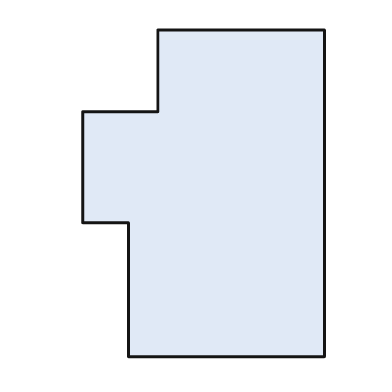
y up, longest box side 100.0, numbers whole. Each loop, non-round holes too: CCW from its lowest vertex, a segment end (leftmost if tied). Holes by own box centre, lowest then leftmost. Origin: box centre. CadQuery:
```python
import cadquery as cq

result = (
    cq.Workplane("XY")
    .moveTo(-23.0, -50.0)
    .lineTo(37.0, -50.0)
    .lineTo(37.0, 50.0)
    .lineTo(-14.0, 50.0)
    .lineTo(-14.0, 25.0)
    .lineTo(-37.0, 25.0)
    .lineTo(-37.0, -9.0)
    .lineTo(-23.0, -9.0)
    .close()
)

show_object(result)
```